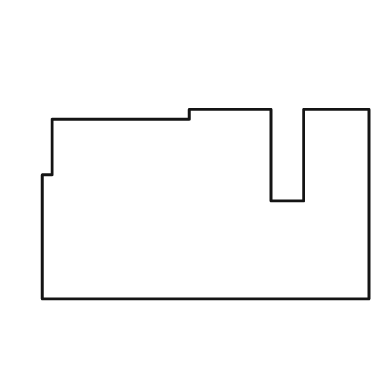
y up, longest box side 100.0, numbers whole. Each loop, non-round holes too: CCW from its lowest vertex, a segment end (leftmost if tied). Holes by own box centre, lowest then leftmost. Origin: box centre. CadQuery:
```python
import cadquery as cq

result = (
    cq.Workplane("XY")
    .moveTo(-50.0, -29.0)
    .lineTo(50.0, -29.0)
    .lineTo(50.0, 29.0)
    .lineTo(30.0, 29.0)
    .lineTo(30.0, 1.0)
    .lineTo(20.0, 1.0)
    .lineTo(20.0, 29.0)
    .lineTo(-5.0, 29.0)
    .lineTo(-5.0, 26.0)
    .lineTo(-47.0, 26.0)
    .lineTo(-47.0, 9.0)
    .lineTo(-50.0, 9.0)
    .close()
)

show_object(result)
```